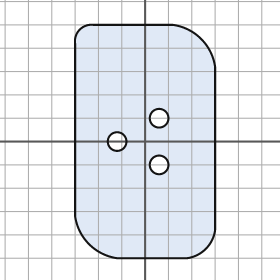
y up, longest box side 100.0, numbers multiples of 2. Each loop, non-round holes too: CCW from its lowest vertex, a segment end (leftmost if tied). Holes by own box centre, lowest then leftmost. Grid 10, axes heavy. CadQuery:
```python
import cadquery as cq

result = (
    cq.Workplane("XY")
    .moveTo(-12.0, -50.0)
    .lineTo(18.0, -50.0)
    .threePointArc((26.0, -46.0), (30.0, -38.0))
    .lineTo(30.0, 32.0)
    .threePointArc((24.0, 44.0), (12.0, 50.0))
    .lineTo(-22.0, 50.0)
    .threePointArc((-28.0, 48.0), (-30.0, 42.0))
    .lineTo(-30.0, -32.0)
    .threePointArc((-24.0, -44.0), (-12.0, -50.0))
    .close()
    .moveTo(6.0, -10.0)
    .circle(4.0)
    .moveTo(-12.0, 0.0)
    .circle(4.0)
    .moveTo(6.0, 10.0)
    .circle(4.0)
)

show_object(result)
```